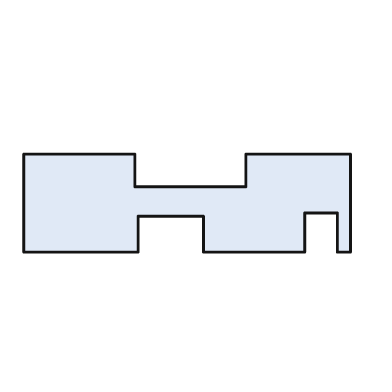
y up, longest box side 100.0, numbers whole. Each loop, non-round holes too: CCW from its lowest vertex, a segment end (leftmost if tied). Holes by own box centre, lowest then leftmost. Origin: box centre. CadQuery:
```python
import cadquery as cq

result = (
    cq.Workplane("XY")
    .moveTo(-50.0, -15.0)
    .lineTo(-15.0, -15.0)
    .lineTo(-15.0, -4.0)
    .lineTo(5.0, -4.0)
    .lineTo(5.0, -15.0)
    .lineTo(36.0, -15.0)
    .lineTo(36.0, -3.0)
    .lineTo(46.0, -3.0)
    .lineTo(46.0, -15.0)
    .lineTo(50.0, -15.0)
    .lineTo(50.0, 15.0)
    .lineTo(18.0, 15.0)
    .lineTo(18.0, 5.0)
    .lineTo(-16.0, 5.0)
    .lineTo(-16.0, 15.0)
    .lineTo(-50.0, 15.0)
    .close()
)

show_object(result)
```